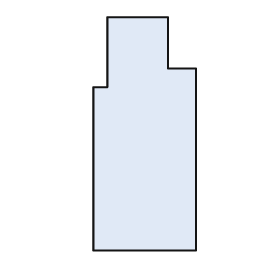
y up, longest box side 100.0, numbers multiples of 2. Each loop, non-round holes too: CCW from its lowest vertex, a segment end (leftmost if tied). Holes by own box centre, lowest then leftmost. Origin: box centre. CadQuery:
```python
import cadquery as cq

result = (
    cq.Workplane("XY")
    .moveTo(-22.0, -50.0)
    .lineTo(22.0, -50.0)
    .lineTo(22.0, 28.0)
    .lineTo(10.0, 28.0)
    .lineTo(10.0, 50.0)
    .lineTo(-16.0, 50.0)
    .lineTo(-16.0, 20.0)
    .lineTo(-22.0, 20.0)
    .close()
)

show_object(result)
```